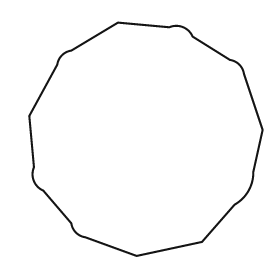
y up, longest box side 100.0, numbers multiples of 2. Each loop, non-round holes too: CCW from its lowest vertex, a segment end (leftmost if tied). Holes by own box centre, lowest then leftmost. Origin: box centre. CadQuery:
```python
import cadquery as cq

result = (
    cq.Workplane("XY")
    .moveTo(-4.0, -50.0)
    .lineTo(24.0, -44.0)
    .lineTo(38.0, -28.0)
    .threePointArc((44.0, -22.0), (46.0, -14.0))
    .lineTo(50.0, 4.0)
    .lineTo(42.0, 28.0)
    .threePointArc((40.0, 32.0), (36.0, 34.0))
    .lineTo(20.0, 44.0)
    .threePointArc((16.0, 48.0), (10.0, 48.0))
    .lineTo(-12.0, 50.0)
    .lineTo(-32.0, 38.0)
    .threePointArc((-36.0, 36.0), (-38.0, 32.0))
    .lineTo(-50.0, 10.0)
    .lineTo(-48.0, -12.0)
    .threePointArc((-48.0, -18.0), (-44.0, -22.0))
    .lineTo(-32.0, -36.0)
    .threePointArc((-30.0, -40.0), (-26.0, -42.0))
    .close()
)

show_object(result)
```